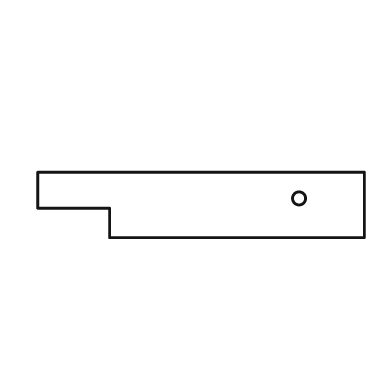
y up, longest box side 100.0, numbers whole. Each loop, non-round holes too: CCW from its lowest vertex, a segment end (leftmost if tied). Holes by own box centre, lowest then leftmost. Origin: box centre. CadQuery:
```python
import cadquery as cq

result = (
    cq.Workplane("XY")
    .moveTo(-28.0, -10.0)
    .lineTo(50.0, -10.0)
    .lineTo(50.0, 10.0)
    .lineTo(-50.0, 10.0)
    .lineTo(-50.0, -1.0)
    .lineTo(-28.0, -1.0)
    .close()
    .moveTo(30.0, 2.0)
    .circle(2.0)
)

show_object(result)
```